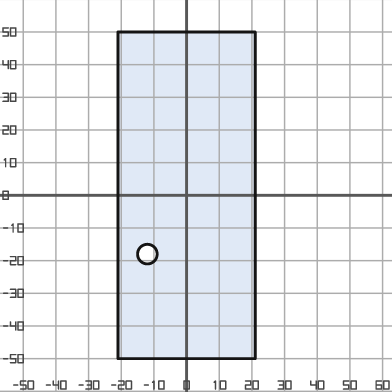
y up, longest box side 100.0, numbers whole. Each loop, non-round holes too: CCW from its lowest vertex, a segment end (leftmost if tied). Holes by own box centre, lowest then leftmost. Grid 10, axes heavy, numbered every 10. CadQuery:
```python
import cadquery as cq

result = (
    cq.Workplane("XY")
    .moveTo(-21.0, -50.0)
    .lineTo(21.0, -50.0)
    .lineTo(21.0, 50.0)
    .lineTo(-21.0, 50.0)
    .close()
    .moveTo(-12.0, -18.0)
    .circle(3.0)
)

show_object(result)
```